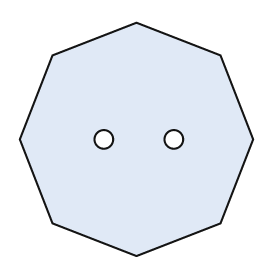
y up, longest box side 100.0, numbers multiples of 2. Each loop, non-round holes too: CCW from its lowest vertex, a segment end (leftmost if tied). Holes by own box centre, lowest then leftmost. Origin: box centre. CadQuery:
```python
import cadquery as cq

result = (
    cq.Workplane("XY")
    .moveTo(0.0, -50.0)
    .lineTo(36.0, -36.0)
    .lineTo(50.0, 0.0)
    .lineTo(36.0, 36.0)
    .lineTo(0.0, 50.0)
    .lineTo(-36.0, 36.0)
    .lineTo(-50.0, 0.0)
    .lineTo(-36.0, -36.0)
    .close()
    .moveTo(-14.0, 0.0)
    .circle(4.0)
    .moveTo(16.0, 0.0)
    .circle(4.0)
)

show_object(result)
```